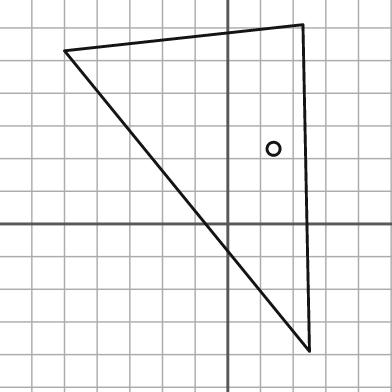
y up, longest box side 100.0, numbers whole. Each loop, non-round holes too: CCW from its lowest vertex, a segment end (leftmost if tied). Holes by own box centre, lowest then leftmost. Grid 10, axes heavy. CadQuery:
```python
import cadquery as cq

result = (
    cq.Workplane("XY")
    .moveTo(25.0, -39.0)
    .lineTo(23.0, 61.0)
    .lineTo(-50.0, 53.0)
    .close()
    .moveTo(14.0, 23.0)
    .circle(2.0)
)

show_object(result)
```